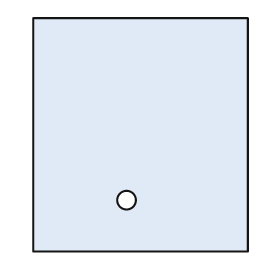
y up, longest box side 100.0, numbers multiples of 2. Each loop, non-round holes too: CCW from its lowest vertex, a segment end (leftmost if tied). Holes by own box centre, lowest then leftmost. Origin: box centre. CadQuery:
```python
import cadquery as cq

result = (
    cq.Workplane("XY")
    .moveTo(-46.0, -50.0)
    .lineTo(46.0, -50.0)
    .lineTo(46.0, 50.0)
    .lineTo(-46.0, 50.0)
    .close()
    .moveTo(-6.0, -28.0)
    .circle(4.0)
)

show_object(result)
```